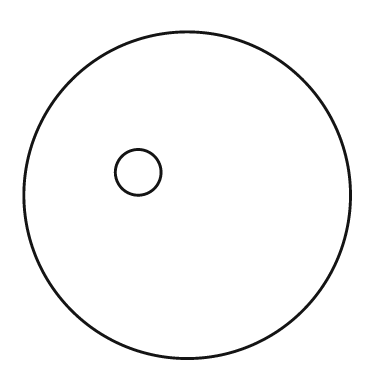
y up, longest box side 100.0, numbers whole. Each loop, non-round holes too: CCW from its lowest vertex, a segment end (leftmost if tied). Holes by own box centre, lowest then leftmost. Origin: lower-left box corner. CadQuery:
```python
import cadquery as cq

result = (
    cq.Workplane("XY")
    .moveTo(50.0, 50.0)
    .circle(50.0)
    .moveTo(35.0, 57.0)
    .circle(7.0)
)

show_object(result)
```